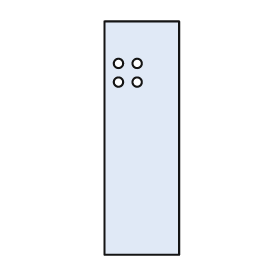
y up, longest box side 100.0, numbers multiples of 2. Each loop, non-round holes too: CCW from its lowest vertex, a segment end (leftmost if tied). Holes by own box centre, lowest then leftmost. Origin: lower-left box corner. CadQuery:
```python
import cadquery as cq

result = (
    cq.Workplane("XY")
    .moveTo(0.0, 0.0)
    .lineTo(32.0, 0.0)
    .lineTo(32.0, 100.0)
    .lineTo(0.0, 100.0)
    .close()
    .moveTo(6.0, 74.0)
    .circle(2.0)
    .moveTo(14.0, 74.0)
    .circle(2.0)
    .moveTo(6.0, 82.0)
    .circle(2.0)
    .moveTo(14.0, 82.0)
    .circle(2.0)
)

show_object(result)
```